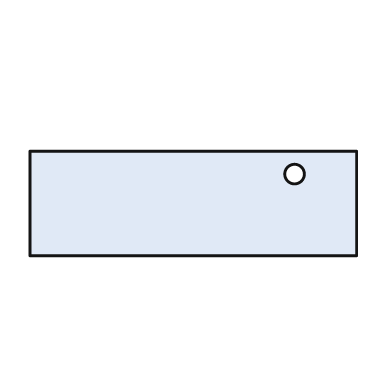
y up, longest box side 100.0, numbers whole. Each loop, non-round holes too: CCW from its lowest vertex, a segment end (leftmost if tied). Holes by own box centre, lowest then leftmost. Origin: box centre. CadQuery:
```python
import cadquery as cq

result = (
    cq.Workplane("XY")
    .moveTo(-50.0, -16.0)
    .lineTo(50.0, -16.0)
    .lineTo(50.0, 16.0)
    .lineTo(-50.0, 16.0)
    .close()
    .moveTo(31.0, 9.0)
    .circle(3.0)
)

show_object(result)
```